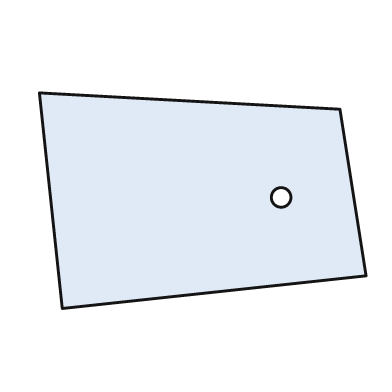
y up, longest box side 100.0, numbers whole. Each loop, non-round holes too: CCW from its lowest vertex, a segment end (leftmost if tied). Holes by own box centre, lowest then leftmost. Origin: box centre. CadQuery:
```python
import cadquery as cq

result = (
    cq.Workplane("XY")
    .moveTo(-43.0, -33.0)
    .lineTo(50.0, -23.0)
    .lineTo(42.0, 28.0)
    .lineTo(-50.0, 33.0)
    .close()
    .moveTo(24.0, 1.0)
    .circle(3.0)
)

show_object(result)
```